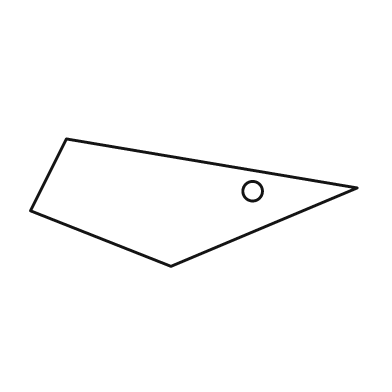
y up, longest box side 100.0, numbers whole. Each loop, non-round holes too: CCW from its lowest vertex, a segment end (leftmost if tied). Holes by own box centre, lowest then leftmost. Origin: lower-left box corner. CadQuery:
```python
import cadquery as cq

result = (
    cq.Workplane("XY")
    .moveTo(43.0, 0.0)
    .lineTo(100.0, 24.0)
    .lineTo(11.0, 39.0)
    .lineTo(0.0, 17.0)
    .close()
    .moveTo(68.0, 23.0)
    .circle(3.0)
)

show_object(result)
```